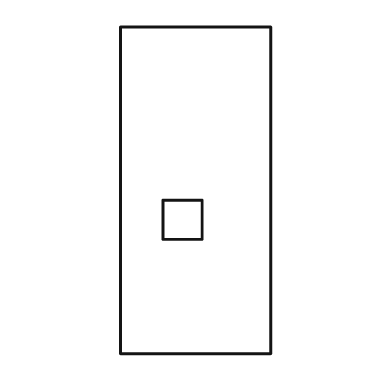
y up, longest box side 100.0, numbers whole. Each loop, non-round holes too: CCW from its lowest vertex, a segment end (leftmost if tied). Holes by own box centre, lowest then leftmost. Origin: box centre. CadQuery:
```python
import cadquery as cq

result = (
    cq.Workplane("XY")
    .moveTo(-23.0, -50.0)
    .lineTo(23.0, -50.0)
    .lineTo(23.0, 50.0)
    .lineTo(-23.0, 50.0)
    .close()
    .moveTo(-10.0, -15.0)
    .lineTo(2.0, -15.0)
    .lineTo(2.0, -3.0)
    .lineTo(-10.0, -3.0)
    .close()
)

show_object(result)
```